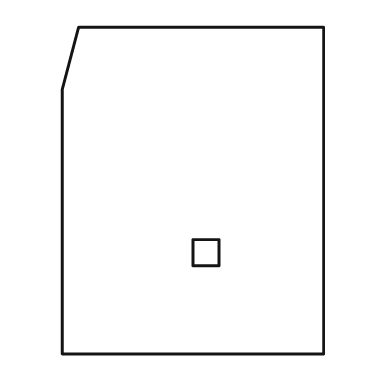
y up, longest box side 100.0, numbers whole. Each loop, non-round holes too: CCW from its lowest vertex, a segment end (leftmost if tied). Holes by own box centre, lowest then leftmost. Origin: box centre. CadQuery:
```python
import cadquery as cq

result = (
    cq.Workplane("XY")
    .moveTo(-40.0, -50.0)
    .lineTo(40.0, -50.0)
    .lineTo(40.0, 50.0)
    .lineTo(-35.0, 50.0)
    .lineTo(-40.0, 31.0)
    .close()
    .moveTo(0.0, -23.0)
    .lineTo(8.0, -23.0)
    .lineTo(8.0, -15.0)
    .lineTo(0.0, -15.0)
    .close()
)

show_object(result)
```